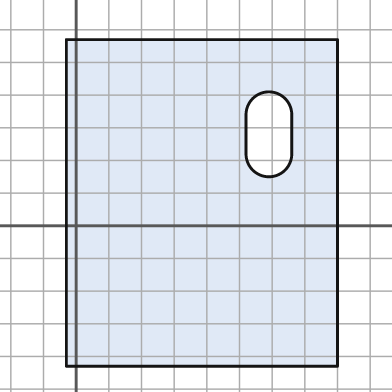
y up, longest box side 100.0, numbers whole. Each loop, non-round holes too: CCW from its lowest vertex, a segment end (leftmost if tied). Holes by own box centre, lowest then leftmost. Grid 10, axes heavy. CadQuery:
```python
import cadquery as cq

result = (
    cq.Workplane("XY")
    .moveTo(-3.0, -43.0)
    .lineTo(80.0, -43.0)
    .lineTo(80.0, 57.0)
    .lineTo(-3.0, 57.0)
    .close()
    .moveTo(52.0, 22.0)
    .threePointArc((59.0, 15.0), (66.0, 22.0))
    .lineTo(66.0, 34.0)
    .threePointArc((59.0, 41.0), (52.0, 34.0))
    .close()
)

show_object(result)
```